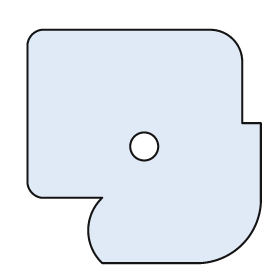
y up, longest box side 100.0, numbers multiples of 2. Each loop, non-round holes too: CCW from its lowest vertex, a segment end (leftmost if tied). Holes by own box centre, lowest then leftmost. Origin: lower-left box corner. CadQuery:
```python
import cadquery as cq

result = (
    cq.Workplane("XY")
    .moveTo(32.0, 0.0)
    .lineTo(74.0, 0.0)
    .threePointArc((92.0, 8.0), (100.0, 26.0))
    .lineTo(100.0, 60.0)
    .lineTo(92.0, 60.0)
    .lineTo(92.0, 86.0)
    .threePointArc((88.0, 96.0), (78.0, 100.0))
    .lineTo(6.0, 100.0)
    .threePointArc((2.0, 98.0), (0.0, 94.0))
    .lineTo(0.0, 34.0)
    .threePointArc((2.0, 30.0), (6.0, 28.0))
    .lineTo(32.0, 28.0)
    .threePointArc((26.0, 14.0), (32.0, 0.0))
    .close()
    .moveTo(50.0, 50.0)
    .circle(6.0)
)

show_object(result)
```